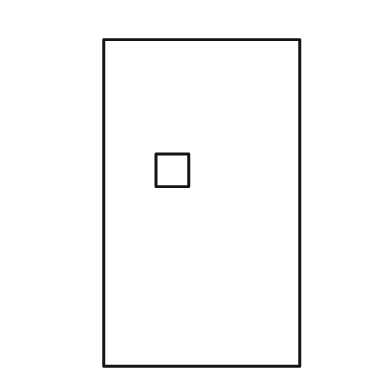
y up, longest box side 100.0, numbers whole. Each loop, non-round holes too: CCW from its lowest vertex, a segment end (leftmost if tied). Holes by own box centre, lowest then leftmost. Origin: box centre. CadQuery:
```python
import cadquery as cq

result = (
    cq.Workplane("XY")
    .moveTo(-30.0, -50.0)
    .lineTo(30.0, -50.0)
    .lineTo(30.0, 50.0)
    .lineTo(-30.0, 50.0)
    .close()
    .moveTo(-14.0, 5.0)
    .lineTo(-4.0, 5.0)
    .lineTo(-4.0, 15.0)
    .lineTo(-14.0, 15.0)
    .close()
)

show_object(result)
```